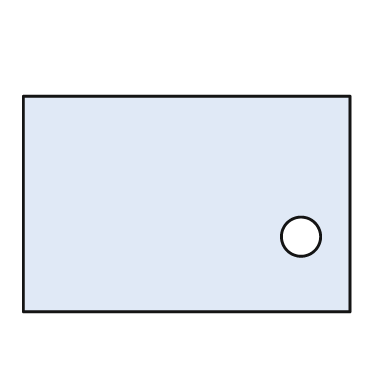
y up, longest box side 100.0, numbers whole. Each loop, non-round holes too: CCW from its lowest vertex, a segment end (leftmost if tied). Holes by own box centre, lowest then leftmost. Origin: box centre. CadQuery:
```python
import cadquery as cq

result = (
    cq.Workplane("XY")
    .moveTo(-50.0, -33.0)
    .lineTo(50.0, -33.0)
    .lineTo(50.0, 33.0)
    .lineTo(-50.0, 33.0)
    .close()
    .moveTo(35.0, -10.0)
    .circle(6.0)
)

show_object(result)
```